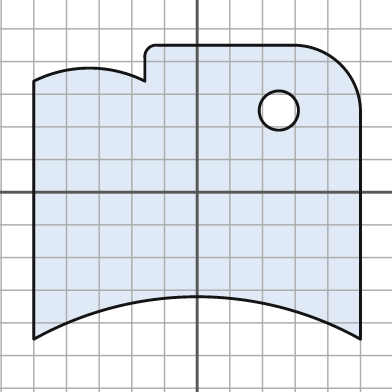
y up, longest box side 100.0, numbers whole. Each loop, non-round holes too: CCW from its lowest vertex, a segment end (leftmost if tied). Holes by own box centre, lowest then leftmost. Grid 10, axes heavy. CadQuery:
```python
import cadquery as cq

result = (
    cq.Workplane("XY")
    .moveTo(-50.0, -45.0)
    .threePointArc((0.0, -32.0), (50.0, -45.0))
    .lineTo(50.0, 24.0)
    .threePointArc((44.0, 39.0), (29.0, 45.0))
    .lineTo(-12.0, 45.0)
    .threePointArc((-15.0, 44.0), (-16.0, 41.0))
    .lineTo(-16.0, 34.0)
    .threePointArc((-33.0, 38.0), (-50.0, 34.0))
    .close()
    .moveTo(25.0, 25.0)
    .circle(6.0)
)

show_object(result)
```